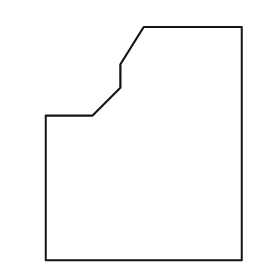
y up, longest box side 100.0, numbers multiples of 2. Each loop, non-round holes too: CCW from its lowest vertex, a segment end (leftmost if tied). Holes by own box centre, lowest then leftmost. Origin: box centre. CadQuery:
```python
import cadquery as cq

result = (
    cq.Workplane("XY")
    .moveTo(-42.0, -50.0)
    .lineTo(42.0, -50.0)
    .lineTo(42.0, 50.0)
    .lineTo(0.0, 50.0)
    .lineTo(-10.0, 34.0)
    .lineTo(-10.0, 24.0)
    .lineTo(-22.0, 12.0)
    .lineTo(-42.0, 12.0)
    .close()
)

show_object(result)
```